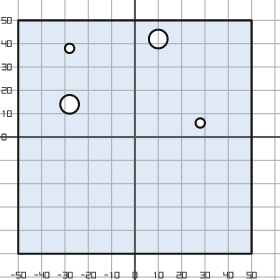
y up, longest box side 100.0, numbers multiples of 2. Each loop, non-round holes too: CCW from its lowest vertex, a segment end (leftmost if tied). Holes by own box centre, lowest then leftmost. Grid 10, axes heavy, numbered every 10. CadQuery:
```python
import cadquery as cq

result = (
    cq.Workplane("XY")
    .moveTo(-50.0, -50.0)
    .lineTo(50.0, -50.0)
    .lineTo(50.0, 50.0)
    .lineTo(-50.0, 50.0)
    .close()
    .moveTo(28.0, 6.0)
    .circle(2.0)
    .moveTo(-28.0, 14.0)
    .circle(4.0)
    .moveTo(-28.0, 38.0)
    .circle(2.0)
    .moveTo(10.0, 42.0)
    .circle(4.0)
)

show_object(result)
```